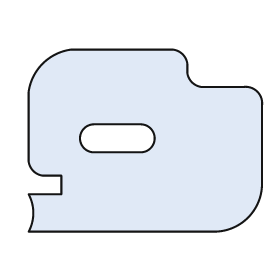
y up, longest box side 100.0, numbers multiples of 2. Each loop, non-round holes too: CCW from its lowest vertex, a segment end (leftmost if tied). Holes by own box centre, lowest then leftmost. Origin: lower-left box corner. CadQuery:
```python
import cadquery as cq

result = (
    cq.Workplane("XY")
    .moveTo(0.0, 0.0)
    .lineTo(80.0, 0.0)
    .threePointArc((94.0, 6.0), (100.0, 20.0))
    .lineTo(100.0, 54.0)
    .threePointArc((98.0, 60.0), (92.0, 62.0))
    .lineTo(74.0, 62.0)
    .threePointArc((70.0, 64.0), (68.0, 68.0))
    .lineTo(68.0, 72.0)
    .threePointArc((66.0, 76.0), (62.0, 78.0))
    .lineTo(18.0, 78.0)
    .threePointArc((6.0, 72.0), (0.0, 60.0))
    .lineTo(0.0, 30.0)
    .threePointArc((2.0, 26.0), (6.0, 24.0))
    .lineTo(14.0, 24.0)
    .lineTo(14.0, 16.0)
    .lineTo(0.0, 16.0)
    .threePointArc((2.0, 8.0), (0.0, 0.0))
    .close()
    .moveTo(28.0, 34.0)
    .lineTo(48.0, 34.0)
    .threePointArc((54.0, 40.0), (48.0, 46.0))
    .lineTo(28.0, 46.0)
    .threePointArc((22.0, 40.0), (28.0, 34.0))
    .close()
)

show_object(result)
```